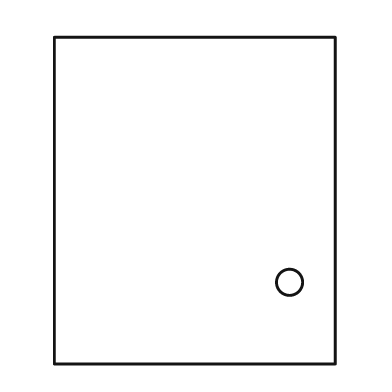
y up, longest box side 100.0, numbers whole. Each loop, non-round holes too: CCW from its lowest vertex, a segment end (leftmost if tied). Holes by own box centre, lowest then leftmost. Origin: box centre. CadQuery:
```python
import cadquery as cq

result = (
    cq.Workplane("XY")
    .moveTo(-43.0, -50.0)
    .lineTo(43.0, -50.0)
    .lineTo(43.0, 50.0)
    .lineTo(-43.0, 50.0)
    .close()
    .moveTo(29.0, -25.0)
    .circle(4.0)
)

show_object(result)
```